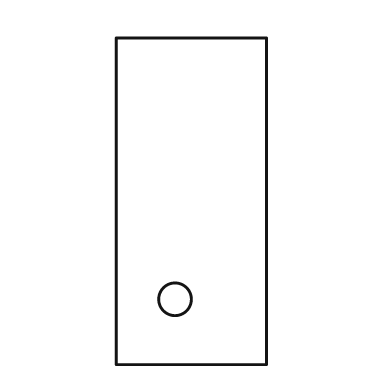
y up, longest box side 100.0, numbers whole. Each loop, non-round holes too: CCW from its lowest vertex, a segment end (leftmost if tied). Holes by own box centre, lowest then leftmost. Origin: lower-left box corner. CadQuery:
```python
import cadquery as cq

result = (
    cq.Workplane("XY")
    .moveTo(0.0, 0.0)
    .lineTo(46.0, 0.0)
    .lineTo(46.0, 100.0)
    .lineTo(0.0, 100.0)
    .close()
    .moveTo(18.0, 20.0)
    .circle(5.0)
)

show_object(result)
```